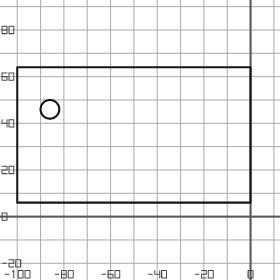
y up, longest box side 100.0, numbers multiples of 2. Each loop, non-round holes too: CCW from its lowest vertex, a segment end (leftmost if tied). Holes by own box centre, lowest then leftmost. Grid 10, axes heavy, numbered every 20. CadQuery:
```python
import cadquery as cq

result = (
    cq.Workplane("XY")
    .moveTo(-100.0, 6.0)
    .lineTo(0.0, 6.0)
    .lineTo(0.0, 64.0)
    .lineTo(-100.0, 64.0)
    .close()
    .moveTo(-86.0, 46.0)
    .circle(4.0)
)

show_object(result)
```